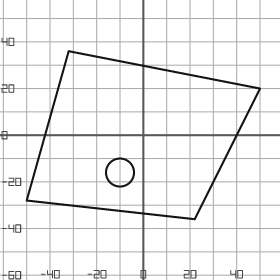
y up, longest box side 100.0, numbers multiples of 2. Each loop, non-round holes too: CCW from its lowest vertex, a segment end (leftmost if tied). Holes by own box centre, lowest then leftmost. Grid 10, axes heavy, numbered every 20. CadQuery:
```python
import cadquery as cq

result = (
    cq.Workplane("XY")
    .moveTo(22.0, -36.0)
    .lineTo(50.0, 20.0)
    .lineTo(-32.0, 36.0)
    .lineTo(-50.0, -28.0)
    .close()
    .moveTo(-10.0, -16.0)
    .circle(6.0)
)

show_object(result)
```